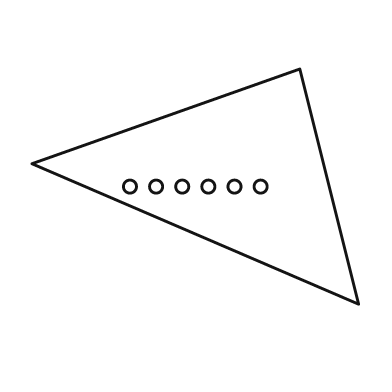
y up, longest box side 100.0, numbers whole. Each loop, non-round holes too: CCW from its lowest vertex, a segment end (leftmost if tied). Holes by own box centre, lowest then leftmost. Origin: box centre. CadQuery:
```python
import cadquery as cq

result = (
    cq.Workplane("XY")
    .moveTo(50.0, -36.0)
    .lineTo(32.0, 36.0)
    .lineTo(-50.0, 7.0)
    .close()
    .moveTo(-20.0, 0.0)
    .circle(2.0)
    .moveTo(-12.0, 0.0)
    .circle(2.0)
    .moveTo(-4.0, 0.0)
    .circle(2.0)
    .moveTo(4.0, 0.0)
    .circle(2.0)
    .moveTo(12.0, 0.0)
    .circle(2.0)
    .moveTo(20.0, 0.0)
    .circle(2.0)
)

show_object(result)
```